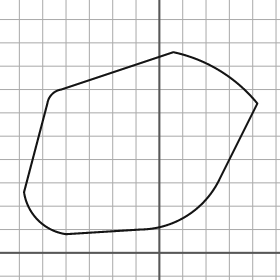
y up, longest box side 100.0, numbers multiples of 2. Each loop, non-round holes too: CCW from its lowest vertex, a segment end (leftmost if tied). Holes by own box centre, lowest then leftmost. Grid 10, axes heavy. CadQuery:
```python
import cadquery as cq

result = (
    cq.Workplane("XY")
    .moveTo(-40.0, 8.0)
    .lineTo(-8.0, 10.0)
    .threePointArc((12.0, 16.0), (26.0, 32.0))
    .lineTo(42.0, 64.0)
    .threePointArc((26.0, 78.0), (6.0, 86.0))
    .lineTo(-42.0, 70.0)
    .threePointArc((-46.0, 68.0), (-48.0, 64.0))
    .lineTo(-58.0, 26.0)
    .threePointArc((-52.0, 14.0), (-40.0, 8.0))
    .close()
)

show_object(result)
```